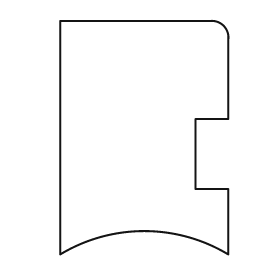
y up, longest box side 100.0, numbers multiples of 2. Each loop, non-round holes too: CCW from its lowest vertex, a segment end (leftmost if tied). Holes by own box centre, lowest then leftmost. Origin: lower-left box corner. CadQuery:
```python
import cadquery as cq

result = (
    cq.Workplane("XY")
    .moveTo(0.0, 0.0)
    .threePointArc((36.0, 10.0), (72.0, 0.0))
    .lineTo(72.0, 28.0)
    .lineTo(58.0, 28.0)
    .lineTo(58.0, 58.0)
    .lineTo(72.0, 58.0)
    .lineTo(72.0, 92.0)
    .threePointArc((70.0, 98.0), (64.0, 100.0))
    .lineTo(0.0, 100.0)
    .close()
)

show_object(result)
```